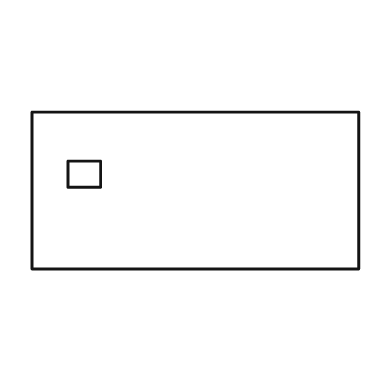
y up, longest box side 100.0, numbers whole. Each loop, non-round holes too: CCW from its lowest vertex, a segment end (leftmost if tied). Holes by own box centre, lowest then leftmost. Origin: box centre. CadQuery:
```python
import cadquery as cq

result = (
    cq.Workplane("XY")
    .moveTo(-50.0, -24.0)
    .lineTo(50.0, -24.0)
    .lineTo(50.0, 24.0)
    .lineTo(-50.0, 24.0)
    .close()
    .moveTo(-39.0, 1.0)
    .lineTo(-29.0, 1.0)
    .lineTo(-29.0, 9.0)
    .lineTo(-39.0, 9.0)
    .close()
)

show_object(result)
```